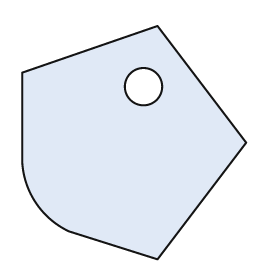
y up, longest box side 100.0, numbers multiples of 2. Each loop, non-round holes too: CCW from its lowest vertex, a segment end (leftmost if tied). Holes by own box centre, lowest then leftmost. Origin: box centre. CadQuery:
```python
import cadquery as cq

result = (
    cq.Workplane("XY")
    .moveTo(10.0, -50.0)
    .lineTo(48.0, 0.0)
    .lineTo(10.0, 50.0)
    .lineTo(-48.0, 30.0)
    .lineTo(-48.0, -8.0)
    .threePointArc((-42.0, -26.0), (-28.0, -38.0))
    .close()
    .moveTo(4.0, 24.0)
    .circle(8.0)
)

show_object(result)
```